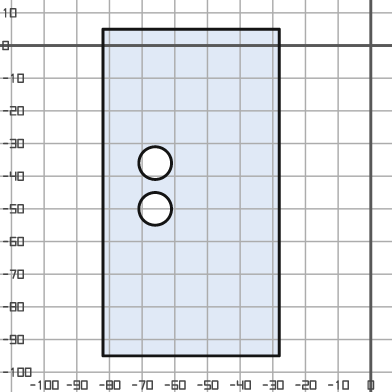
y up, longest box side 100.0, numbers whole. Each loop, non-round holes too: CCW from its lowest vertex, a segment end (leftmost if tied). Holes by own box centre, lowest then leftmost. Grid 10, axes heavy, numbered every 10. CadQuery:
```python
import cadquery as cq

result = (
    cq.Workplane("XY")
    .moveTo(-82.0, -95.0)
    .lineTo(-28.0, -95.0)
    .lineTo(-28.0, 5.0)
    .lineTo(-82.0, 5.0)
    .close()
    .moveTo(-66.0, -50.0)
    .circle(5.0)
    .moveTo(-66.0, -36.0)
    .circle(5.0)
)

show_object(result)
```